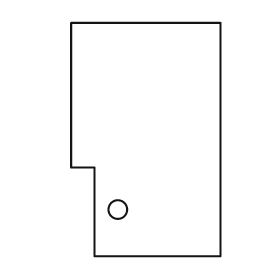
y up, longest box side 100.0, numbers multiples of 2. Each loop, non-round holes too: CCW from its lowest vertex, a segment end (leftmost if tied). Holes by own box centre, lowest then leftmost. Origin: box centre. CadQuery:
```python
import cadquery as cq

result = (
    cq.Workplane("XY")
    .moveTo(-22.0, -50.0)
    .lineTo(32.0, -50.0)
    .lineTo(32.0, 50.0)
    .lineTo(-32.0, 50.0)
    .lineTo(-32.0, -12.0)
    .lineTo(-22.0, -12.0)
    .close()
    .moveTo(-12.0, -30.0)
    .circle(4.0)
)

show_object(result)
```